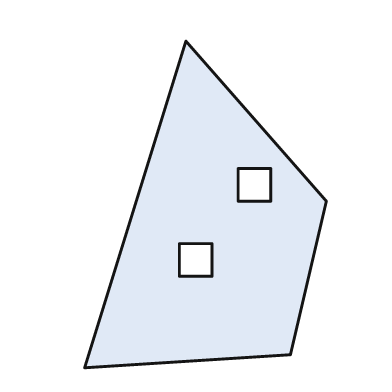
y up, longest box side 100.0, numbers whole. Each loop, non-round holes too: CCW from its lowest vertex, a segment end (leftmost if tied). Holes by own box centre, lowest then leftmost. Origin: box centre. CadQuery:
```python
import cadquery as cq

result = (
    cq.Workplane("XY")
    .moveTo(-37.0, -50.0)
    .lineTo(26.0, -46.0)
    .lineTo(37.0, 1.0)
    .lineTo(-6.0, 50.0)
    .close()
    .moveTo(-8.0, -22.0)
    .lineTo(2.0, -22.0)
    .lineTo(2.0, -12.0)
    .lineTo(-8.0, -12.0)
    .close()
    .moveTo(10.0, 1.0)
    .lineTo(20.0, 1.0)
    .lineTo(20.0, 11.0)
    .lineTo(10.0, 11.0)
    .close()
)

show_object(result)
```